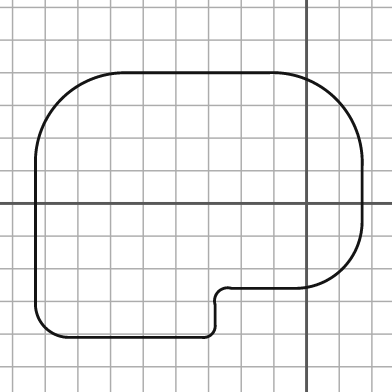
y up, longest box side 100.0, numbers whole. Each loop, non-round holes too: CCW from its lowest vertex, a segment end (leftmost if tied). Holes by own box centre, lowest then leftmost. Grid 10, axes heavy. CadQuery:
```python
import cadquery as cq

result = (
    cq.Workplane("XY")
    .moveTo(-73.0, -41.0)
    .lineTo(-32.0, -41.0)
    .threePointArc((-29.0, -40.0), (-28.0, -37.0))
    .lineTo(-28.0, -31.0)
    .threePointArc((-27.0, -27.0), (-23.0, -26.0))
    .lineTo(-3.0, -26.0)
    .threePointArc((11.0, -20.0), (17.0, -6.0))
    .lineTo(17.0, 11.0)
    .threePointArc((9.0, 32.0), (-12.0, 40.0))
    .lineTo(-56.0, 40.0)
    .threePointArc((-75.0, 32.0), (-83.0, 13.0))
    .lineTo(-83.0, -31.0)
    .threePointArc((-80.0, -38.0), (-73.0, -41.0))
    .close()
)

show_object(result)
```